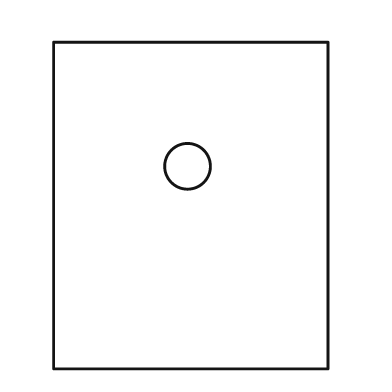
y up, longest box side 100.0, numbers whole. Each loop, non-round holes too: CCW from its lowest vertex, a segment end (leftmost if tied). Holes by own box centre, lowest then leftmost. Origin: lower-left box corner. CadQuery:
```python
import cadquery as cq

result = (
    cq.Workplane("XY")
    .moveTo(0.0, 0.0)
    .lineTo(84.0, 0.0)
    .lineTo(84.0, 100.0)
    .lineTo(0.0, 100.0)
    .close()
    .moveTo(41.0, 62.0)
    .circle(7.0)
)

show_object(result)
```